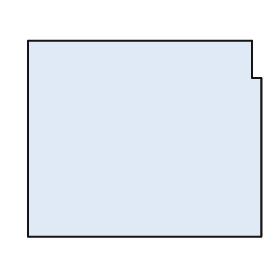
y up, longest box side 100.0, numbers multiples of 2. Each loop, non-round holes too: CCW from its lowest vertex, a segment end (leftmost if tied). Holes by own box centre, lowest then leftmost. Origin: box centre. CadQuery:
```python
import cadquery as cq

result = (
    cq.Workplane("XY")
    .moveTo(-50.0, -42.0)
    .lineTo(50.0, -42.0)
    .lineTo(50.0, 26.0)
    .lineTo(46.0, 26.0)
    .lineTo(46.0, 42.0)
    .lineTo(-50.0, 42.0)
    .close()
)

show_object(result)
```